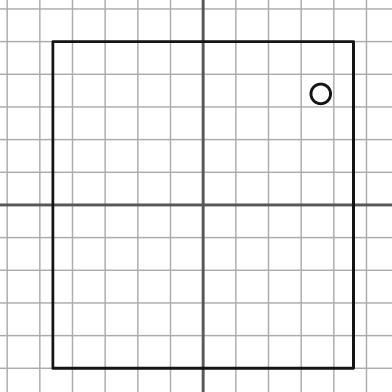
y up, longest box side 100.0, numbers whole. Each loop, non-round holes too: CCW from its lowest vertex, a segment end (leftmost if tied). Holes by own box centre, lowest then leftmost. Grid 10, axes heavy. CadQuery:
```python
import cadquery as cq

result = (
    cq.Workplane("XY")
    .moveTo(-46.0, -50.0)
    .lineTo(46.0, -50.0)
    .lineTo(46.0, 50.0)
    .lineTo(-46.0, 50.0)
    .close()
    .moveTo(36.0, 34.0)
    .circle(3.0)
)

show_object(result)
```